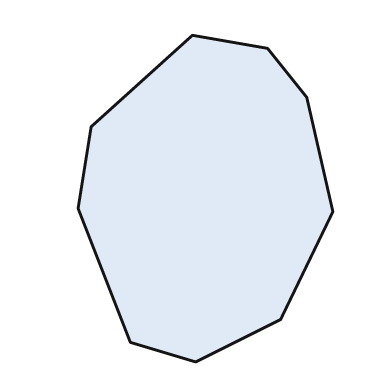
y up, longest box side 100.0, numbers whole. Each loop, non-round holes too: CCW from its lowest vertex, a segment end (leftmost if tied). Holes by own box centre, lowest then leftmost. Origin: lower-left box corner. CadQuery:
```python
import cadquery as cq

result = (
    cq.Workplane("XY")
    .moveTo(36.0, 0.0)
    .lineTo(62.0, 13.0)
    .lineTo(78.0, 46.0)
    .lineTo(70.0, 81.0)
    .lineTo(58.0, 96.0)
    .lineTo(35.0, 100.0)
    .lineTo(4.0, 72.0)
    .lineTo(0.0, 47.0)
    .lineTo(16.0, 6.0)
    .close()
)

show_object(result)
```